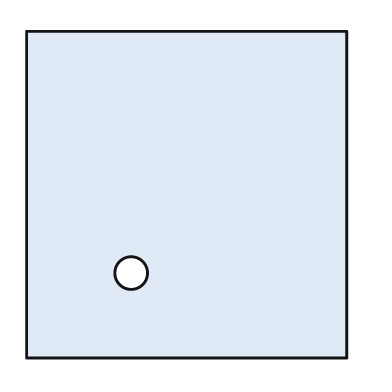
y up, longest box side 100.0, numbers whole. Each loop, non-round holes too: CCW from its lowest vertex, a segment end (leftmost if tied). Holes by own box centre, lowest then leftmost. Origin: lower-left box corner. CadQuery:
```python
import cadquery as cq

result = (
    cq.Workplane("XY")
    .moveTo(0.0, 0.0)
    .lineTo(98.0, 0.0)
    .lineTo(98.0, 100.0)
    .lineTo(0.0, 100.0)
    .close()
    .moveTo(32.0, 26.0)
    .circle(5.0)
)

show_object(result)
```